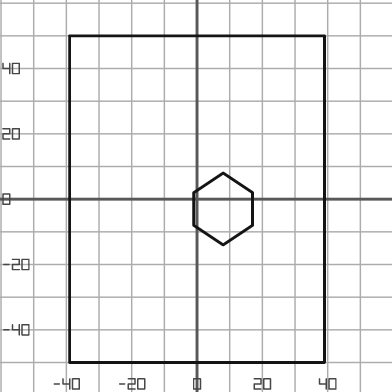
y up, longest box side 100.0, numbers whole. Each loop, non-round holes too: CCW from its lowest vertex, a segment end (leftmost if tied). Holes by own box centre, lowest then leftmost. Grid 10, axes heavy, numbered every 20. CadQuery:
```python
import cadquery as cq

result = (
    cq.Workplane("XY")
    .moveTo(-39.0, -50.0)
    .lineTo(39.0, -50.0)
    .lineTo(39.0, 50.0)
    .lineTo(-39.0, 50.0)
    .close()
    .moveTo(8.0, -14.0)
    .lineTo(17.0, -8.0)
    .lineTo(17.0, 2.0)
    .lineTo(8.0, 8.0)
    .lineTo(-1.0, 2.0)
    .lineTo(-1.0, -8.0)
    .close()
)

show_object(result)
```